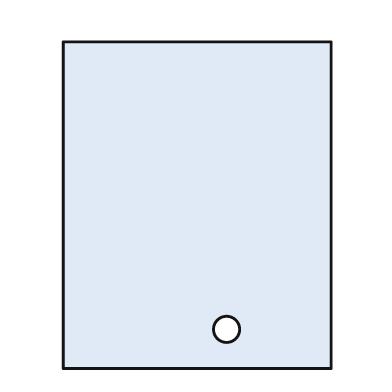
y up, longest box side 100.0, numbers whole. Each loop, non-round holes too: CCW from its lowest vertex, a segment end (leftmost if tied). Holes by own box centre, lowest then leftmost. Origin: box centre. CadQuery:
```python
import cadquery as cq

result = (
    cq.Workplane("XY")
    .moveTo(-41.0, -50.0)
    .lineTo(41.0, -50.0)
    .lineTo(41.0, 50.0)
    .lineTo(-41.0, 50.0)
    .close()
    .moveTo(9.0, -38.0)
    .circle(4.0)
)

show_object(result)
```